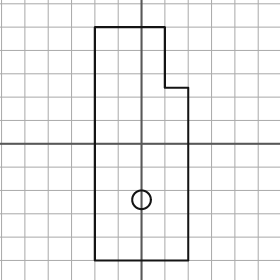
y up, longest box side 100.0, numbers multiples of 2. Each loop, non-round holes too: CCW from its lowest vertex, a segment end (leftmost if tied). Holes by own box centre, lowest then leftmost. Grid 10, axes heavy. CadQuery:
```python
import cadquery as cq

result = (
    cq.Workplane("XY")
    .moveTo(-20.0, -50.0)
    .lineTo(20.0, -50.0)
    .lineTo(20.0, 24.0)
    .lineTo(10.0, 24.0)
    .lineTo(10.0, 50.0)
    .lineTo(-20.0, 50.0)
    .close()
    .moveTo(0.0, -24.0)
    .circle(4.0)
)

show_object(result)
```